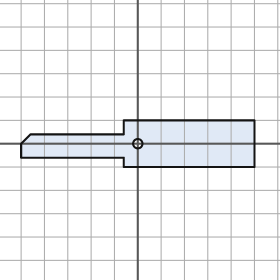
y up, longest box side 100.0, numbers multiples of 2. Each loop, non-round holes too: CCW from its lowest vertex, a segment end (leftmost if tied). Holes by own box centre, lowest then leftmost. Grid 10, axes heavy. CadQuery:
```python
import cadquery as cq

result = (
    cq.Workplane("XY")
    .moveTo(-6.0, -10.0)
    .lineTo(50.0, -10.0)
    .lineTo(50.0, 10.0)
    .lineTo(-6.0, 10.0)
    .lineTo(-6.0, 4.0)
    .lineTo(-46.0, 4.0)
    .lineTo(-50.0, 0.0)
    .lineTo(-50.0, -6.0)
    .lineTo(-6.0, -6.0)
    .close()
    .moveTo(0.0, 0.0)
    .circle(2.0)
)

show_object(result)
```